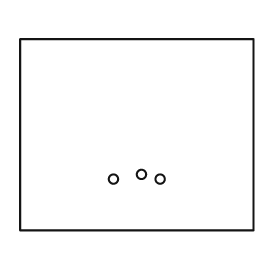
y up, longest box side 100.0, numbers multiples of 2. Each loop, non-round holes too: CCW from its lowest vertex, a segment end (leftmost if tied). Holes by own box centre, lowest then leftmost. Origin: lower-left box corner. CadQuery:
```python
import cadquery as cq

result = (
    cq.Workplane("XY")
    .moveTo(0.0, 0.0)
    .lineTo(100.0, 0.0)
    .lineTo(100.0, 82.0)
    .lineTo(0.0, 82.0)
    .close()
    .moveTo(40.0, 22.0)
    .circle(2.0)
    .moveTo(60.0, 22.0)
    .circle(2.0)
    .moveTo(52.0, 24.0)
    .circle(2.0)
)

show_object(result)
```